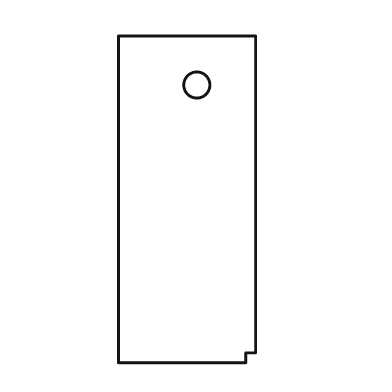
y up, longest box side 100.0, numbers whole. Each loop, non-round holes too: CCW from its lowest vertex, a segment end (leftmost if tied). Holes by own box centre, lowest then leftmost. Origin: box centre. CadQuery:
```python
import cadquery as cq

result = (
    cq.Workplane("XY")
    .moveTo(-21.0, -50.0)
    .lineTo(18.0, -50.0)
    .lineTo(18.0, -47.0)
    .lineTo(21.0, -47.0)
    .lineTo(21.0, 50.0)
    .lineTo(-21.0, 50.0)
    .close()
    .moveTo(3.0, 35.0)
    .circle(4.0)
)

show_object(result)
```